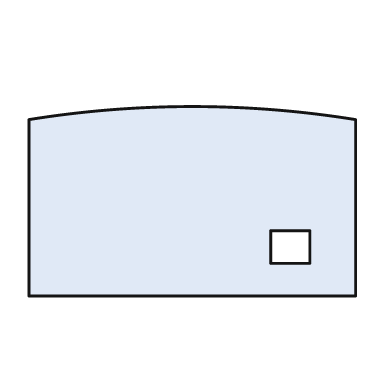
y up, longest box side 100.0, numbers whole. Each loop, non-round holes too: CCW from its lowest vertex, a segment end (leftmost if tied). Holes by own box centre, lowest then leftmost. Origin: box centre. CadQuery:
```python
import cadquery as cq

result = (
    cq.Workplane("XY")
    .moveTo(-50.0, -29.0)
    .lineTo(50.0, -29.0)
    .lineTo(50.0, 25.0)
    .threePointArc((0.0, 29.0), (-50.0, 25.0))
    .close()
    .moveTo(24.0, -19.0)
    .lineTo(36.0, -19.0)
    .lineTo(36.0, -9.0)
    .lineTo(24.0, -9.0)
    .close()
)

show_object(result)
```